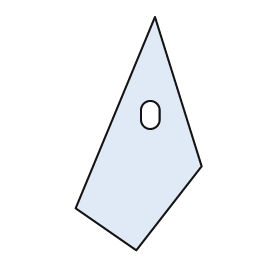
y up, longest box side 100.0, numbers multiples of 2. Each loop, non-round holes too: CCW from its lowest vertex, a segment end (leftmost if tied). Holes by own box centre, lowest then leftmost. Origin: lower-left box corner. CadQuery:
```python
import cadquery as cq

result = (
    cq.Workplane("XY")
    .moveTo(26.0, 0.0)
    .lineTo(54.0, 36.0)
    .lineTo(34.0, 100.0)
    .lineTo(0.0, 18.0)
    .close()
    .moveTo(28.0, 56.0)
    .threePointArc((32.0, 52.0), (36.0, 56.0))
    .lineTo(36.0, 60.0)
    .threePointArc((32.0, 64.0), (28.0, 60.0))
    .close()
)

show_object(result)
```